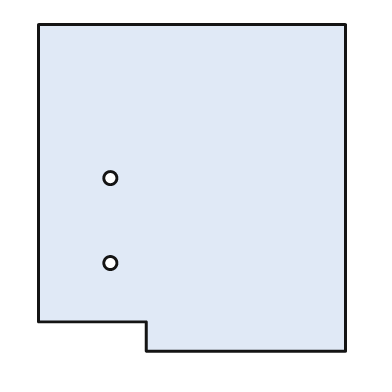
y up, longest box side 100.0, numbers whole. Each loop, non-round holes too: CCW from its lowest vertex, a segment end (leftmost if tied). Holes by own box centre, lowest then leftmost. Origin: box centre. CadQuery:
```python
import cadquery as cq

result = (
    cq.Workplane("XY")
    .moveTo(-14.0, -50.0)
    .lineTo(47.0, -50.0)
    .lineTo(47.0, 50.0)
    .lineTo(-47.0, 50.0)
    .lineTo(-47.0, -41.0)
    .lineTo(-14.0, -41.0)
    .close()
    .moveTo(-25.0, -23.0)
    .circle(2.0)
    .moveTo(-25.0, 3.0)
    .circle(2.0)
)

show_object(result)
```